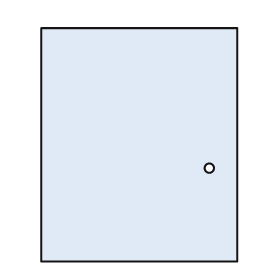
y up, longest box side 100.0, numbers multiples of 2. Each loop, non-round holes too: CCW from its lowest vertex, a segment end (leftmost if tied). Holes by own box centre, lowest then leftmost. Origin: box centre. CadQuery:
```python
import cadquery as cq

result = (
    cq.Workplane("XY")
    .moveTo(-42.0, -50.0)
    .lineTo(42.0, -50.0)
    .lineTo(42.0, 50.0)
    .lineTo(-42.0, 50.0)
    .close()
    .moveTo(30.0, -10.0)
    .circle(2.0)
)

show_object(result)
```